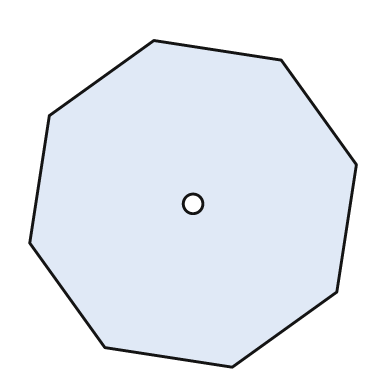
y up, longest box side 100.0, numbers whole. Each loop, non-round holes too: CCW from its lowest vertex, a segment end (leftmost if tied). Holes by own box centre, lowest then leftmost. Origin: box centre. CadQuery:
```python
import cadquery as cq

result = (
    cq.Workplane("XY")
    .moveTo(12.0, -50.0)
    .lineTo(44.0, -27.0)
    .lineTo(50.0, 12.0)
    .lineTo(27.0, 44.0)
    .lineTo(-12.0, 50.0)
    .lineTo(-44.0, 27.0)
    .lineTo(-50.0, -12.0)
    .lineTo(-27.0, -44.0)
    .close()
    .moveTo(0.0, 0.0)
    .circle(3.0)
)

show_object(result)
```